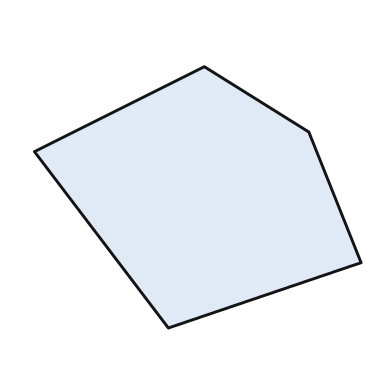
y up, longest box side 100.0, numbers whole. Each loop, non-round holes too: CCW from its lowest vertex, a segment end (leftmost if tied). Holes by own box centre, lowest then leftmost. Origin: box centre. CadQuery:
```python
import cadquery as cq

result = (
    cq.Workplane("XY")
    .moveTo(-9.0, -40.0)
    .lineTo(50.0, -20.0)
    .lineTo(34.0, 20.0)
    .lineTo(2.0, 40.0)
    .lineTo(-50.0, 14.0)
    .close()
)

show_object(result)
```